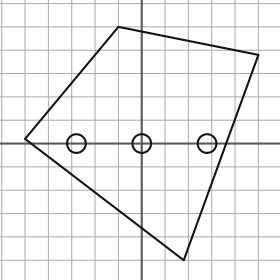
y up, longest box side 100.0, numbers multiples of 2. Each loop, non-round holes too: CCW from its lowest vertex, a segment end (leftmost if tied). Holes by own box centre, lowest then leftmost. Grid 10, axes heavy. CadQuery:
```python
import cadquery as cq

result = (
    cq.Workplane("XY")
    .moveTo(18.0, -50.0)
    .lineTo(50.0, 38.0)
    .lineTo(-10.0, 50.0)
    .lineTo(-50.0, 2.0)
    .close()
    .moveTo(-28.0, 0.0)
    .circle(4.0)
    .moveTo(0.0, 0.0)
    .circle(4.0)
    .moveTo(28.0, 0.0)
    .circle(4.0)
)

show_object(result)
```